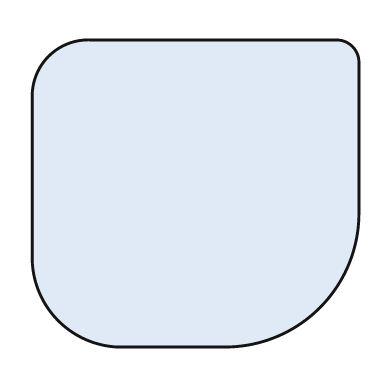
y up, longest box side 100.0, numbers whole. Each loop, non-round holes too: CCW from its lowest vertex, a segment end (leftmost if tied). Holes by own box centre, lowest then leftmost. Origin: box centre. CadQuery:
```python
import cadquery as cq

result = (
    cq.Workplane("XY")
    .moveTo(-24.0, -47.0)
    .lineTo(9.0, -47.0)
    .threePointArc((38.0, -35.0), (50.0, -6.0))
    .lineTo(50.0, 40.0)
    .threePointArc((48.0, 45.0), (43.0, 47.0))
    .lineTo(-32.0, 47.0)
    .threePointArc((-45.0, 42.0), (-50.0, 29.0))
    .lineTo(-50.0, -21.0)
    .threePointArc((-42.0, -39.0), (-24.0, -47.0))
    .close()
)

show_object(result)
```